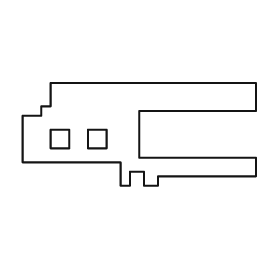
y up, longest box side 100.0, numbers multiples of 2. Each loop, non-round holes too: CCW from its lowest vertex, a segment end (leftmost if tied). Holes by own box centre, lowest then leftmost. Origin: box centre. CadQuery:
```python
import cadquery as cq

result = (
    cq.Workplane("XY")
    .moveTo(-8.0, -22.0)
    .lineTo(-4.0, -22.0)
    .lineTo(-4.0, -16.0)
    .lineTo(2.0, -16.0)
    .lineTo(2.0, -22.0)
    .lineTo(8.0, -22.0)
    .lineTo(8.0, -18.0)
    .lineTo(50.0, -18.0)
    .lineTo(50.0, -10.0)
    .lineTo(0.0, -10.0)
    .lineTo(0.0, 10.0)
    .lineTo(50.0, 10.0)
    .lineTo(50.0, 22.0)
    .lineTo(-38.0, 22.0)
    .lineTo(-38.0, 12.0)
    .lineTo(-42.0, 12.0)
    .lineTo(-42.0, 8.0)
    .lineTo(-50.0, 8.0)
    .lineTo(-50.0, -12.0)
    .lineTo(-8.0, -12.0)
    .close()
    .moveTo(-38.0, -6.0)
    .lineTo(-30.0, -6.0)
    .lineTo(-30.0, 2.0)
    .lineTo(-38.0, 2.0)
    .close()
    .moveTo(-22.0, -6.0)
    .lineTo(-14.0, -6.0)
    .lineTo(-14.0, 2.0)
    .lineTo(-22.0, 2.0)
    .close()
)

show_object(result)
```